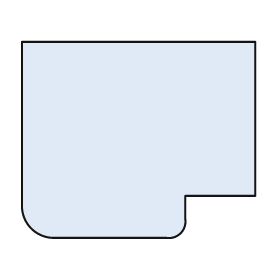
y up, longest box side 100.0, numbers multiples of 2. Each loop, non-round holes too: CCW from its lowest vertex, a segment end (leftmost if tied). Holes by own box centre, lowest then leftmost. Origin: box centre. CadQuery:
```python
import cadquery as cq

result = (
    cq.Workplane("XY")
    .moveTo(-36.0, -42.0)
    .lineTo(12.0, -42.0)
    .threePointArc((18.0, -40.0), (20.0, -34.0))
    .lineTo(20.0, -24.0)
    .lineTo(50.0, -24.0)
    .lineTo(50.0, 42.0)
    .lineTo(-50.0, 42.0)
    .lineTo(-50.0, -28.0)
    .threePointArc((-46.0, -38.0), (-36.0, -42.0))
    .close()
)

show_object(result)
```